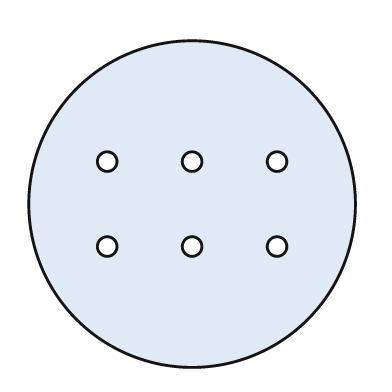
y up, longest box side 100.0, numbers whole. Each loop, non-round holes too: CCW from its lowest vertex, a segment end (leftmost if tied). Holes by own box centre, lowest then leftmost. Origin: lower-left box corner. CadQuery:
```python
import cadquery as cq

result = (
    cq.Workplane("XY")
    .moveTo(50.0, 50.0)
    .circle(50.0)
    .moveTo(24.0, 37.0)
    .circle(3.0)
    .moveTo(50.0, 37.0)
    .circle(3.0)
    .moveTo(76.0, 37.0)
    .circle(3.0)
    .moveTo(24.0, 63.0)
    .circle(3.0)
    .moveTo(50.0, 63.0)
    .circle(3.0)
    .moveTo(76.0, 63.0)
    .circle(3.0)
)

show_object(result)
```